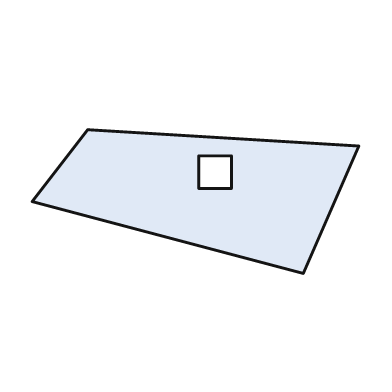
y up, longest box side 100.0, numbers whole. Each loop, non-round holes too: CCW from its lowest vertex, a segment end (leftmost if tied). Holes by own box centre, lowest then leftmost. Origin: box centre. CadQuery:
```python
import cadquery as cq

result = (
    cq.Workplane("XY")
    .moveTo(33.0, -22.0)
    .lineTo(50.0, 17.0)
    .lineTo(-33.0, 22.0)
    .lineTo(-50.0, 0.0)
    .close()
    .moveTo(1.0, 4.0)
    .lineTo(11.0, 4.0)
    .lineTo(11.0, 14.0)
    .lineTo(1.0, 14.0)
    .close()
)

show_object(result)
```